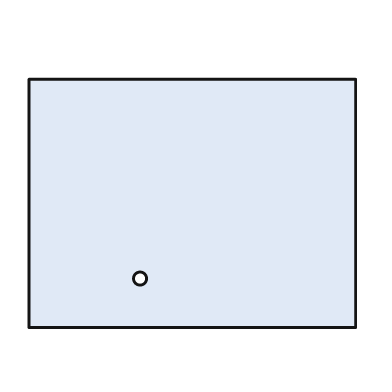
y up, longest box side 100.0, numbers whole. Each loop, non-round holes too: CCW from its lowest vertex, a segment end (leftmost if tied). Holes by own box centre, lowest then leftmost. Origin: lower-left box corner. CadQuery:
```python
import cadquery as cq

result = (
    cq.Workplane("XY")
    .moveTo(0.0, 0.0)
    .lineTo(100.0, 0.0)
    .lineTo(100.0, 76.0)
    .lineTo(0.0, 76.0)
    .close()
    .moveTo(34.0, 15.0)
    .circle(2.0)
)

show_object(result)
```